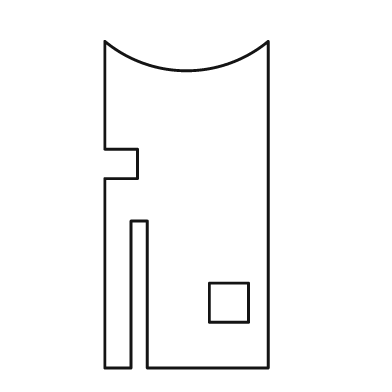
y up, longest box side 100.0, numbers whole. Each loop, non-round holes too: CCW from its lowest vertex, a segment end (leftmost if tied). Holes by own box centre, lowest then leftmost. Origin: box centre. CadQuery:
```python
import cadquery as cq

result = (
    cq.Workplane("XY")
    .moveTo(-25.0, -50.0)
    .lineTo(-17.0, -50.0)
    .lineTo(-17.0, -5.0)
    .lineTo(-12.0, -5.0)
    .lineTo(-12.0, -50.0)
    .lineTo(25.0, -50.0)
    .lineTo(25.0, 50.0)
    .threePointArc((0.0, 41.0), (-25.0, 50.0))
    .lineTo(-25.0, 17.0)
    .lineTo(-15.0, 17.0)
    .lineTo(-15.0, 8.0)
    .lineTo(-25.0, 8.0)
    .close()
    .moveTo(7.0, -36.0)
    .lineTo(19.0, -36.0)
    .lineTo(19.0, -24.0)
    .lineTo(7.0, -24.0)
    .close()
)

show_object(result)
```